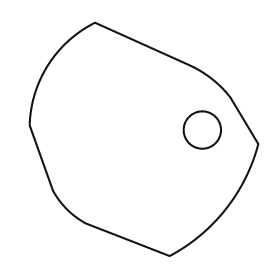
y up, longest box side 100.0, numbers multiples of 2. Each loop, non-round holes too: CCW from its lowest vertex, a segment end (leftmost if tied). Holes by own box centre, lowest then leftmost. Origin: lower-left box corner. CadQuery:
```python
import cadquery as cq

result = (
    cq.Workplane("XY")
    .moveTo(60.0, 0.0)
    .threePointArc((84.0, 20.0), (98.0, 48.0))
    .lineTo(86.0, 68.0)
    .threePointArc((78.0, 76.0), (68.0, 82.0))
    .lineTo(28.0, 100.0)
    .threePointArc((8.0, 82.0), (0.0, 56.0))
    .lineTo(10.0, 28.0)
    .threePointArc((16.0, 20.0), (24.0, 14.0))
    .close()
    .moveTo(74.0, 54.0)
    .circle(8.0)
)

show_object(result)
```